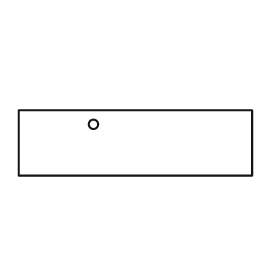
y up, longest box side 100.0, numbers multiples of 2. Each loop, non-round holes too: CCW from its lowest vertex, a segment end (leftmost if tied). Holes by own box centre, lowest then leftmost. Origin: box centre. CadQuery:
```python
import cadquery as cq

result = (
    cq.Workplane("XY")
    .moveTo(-50.0, -14.0)
    .lineTo(50.0, -14.0)
    .lineTo(50.0, 14.0)
    .lineTo(-50.0, 14.0)
    .close()
    .moveTo(-18.0, 8.0)
    .circle(2.0)
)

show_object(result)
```